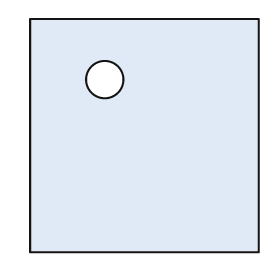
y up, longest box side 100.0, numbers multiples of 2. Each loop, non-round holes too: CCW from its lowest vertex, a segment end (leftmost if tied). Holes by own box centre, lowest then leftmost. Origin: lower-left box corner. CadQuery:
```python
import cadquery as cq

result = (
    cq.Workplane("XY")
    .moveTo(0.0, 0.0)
    .lineTo(98.0, 0.0)
    .lineTo(98.0, 100.0)
    .lineTo(0.0, 100.0)
    .close()
    .moveTo(32.0, 74.0)
    .circle(8.0)
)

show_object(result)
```